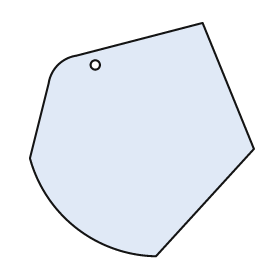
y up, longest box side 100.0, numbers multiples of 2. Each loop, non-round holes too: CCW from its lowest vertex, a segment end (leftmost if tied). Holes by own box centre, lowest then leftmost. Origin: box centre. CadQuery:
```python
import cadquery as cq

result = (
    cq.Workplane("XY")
    .moveTo(6.0, -50.0)
    .lineTo(48.0, -4.0)
    .lineTo(26.0, 50.0)
    .lineTo(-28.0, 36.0)
    .threePointArc((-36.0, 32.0), (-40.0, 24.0))
    .lineTo(-48.0, -8.0)
    .threePointArc((-28.0, -38.0), (6.0, -50.0))
    .close()
    .moveTo(-20.0, 32.0)
    .circle(2.0)
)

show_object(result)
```